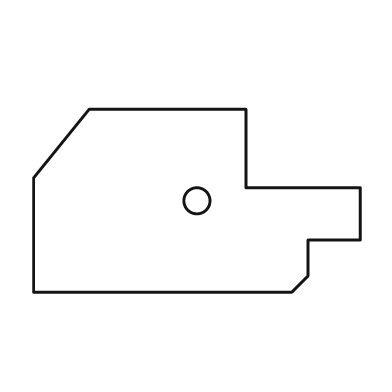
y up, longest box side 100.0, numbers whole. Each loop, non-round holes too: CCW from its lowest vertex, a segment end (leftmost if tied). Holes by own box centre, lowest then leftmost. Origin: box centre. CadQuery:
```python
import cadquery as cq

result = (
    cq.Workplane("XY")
    .moveTo(-50.0, -28.0)
    .lineTo(29.0, -28.0)
    .lineTo(34.0, -23.0)
    .lineTo(34.0, -12.0)
    .lineTo(50.0, -12.0)
    .lineTo(50.0, 4.0)
    .lineTo(15.0, 4.0)
    .lineTo(15.0, 28.0)
    .lineTo(-33.0, 28.0)
    .lineTo(-50.0, 7.0)
    .close()
    .moveTo(0.0, 0.0)
    .circle(4.0)
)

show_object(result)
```